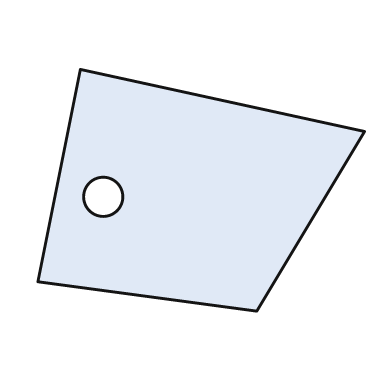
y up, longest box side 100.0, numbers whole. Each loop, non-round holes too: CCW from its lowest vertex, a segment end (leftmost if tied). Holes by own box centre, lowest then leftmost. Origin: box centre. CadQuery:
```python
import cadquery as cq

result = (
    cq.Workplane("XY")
    .moveTo(17.0, -37.0)
    .lineTo(50.0, 18.0)
    .lineTo(-37.0, 37.0)
    .lineTo(-50.0, -28.0)
    .close()
    .moveTo(-30.0, -2.0)
    .circle(6.0)
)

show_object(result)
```